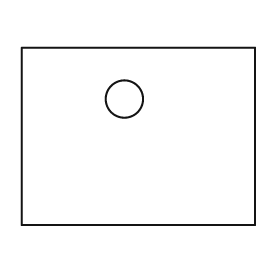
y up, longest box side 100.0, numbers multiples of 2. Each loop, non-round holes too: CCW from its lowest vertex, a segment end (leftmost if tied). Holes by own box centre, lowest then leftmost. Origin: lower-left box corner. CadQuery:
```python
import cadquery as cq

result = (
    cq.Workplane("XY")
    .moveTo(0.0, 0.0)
    .lineTo(100.0, 0.0)
    .lineTo(100.0, 76.0)
    .lineTo(0.0, 76.0)
    .close()
    .moveTo(44.0, 54.0)
    .circle(8.0)
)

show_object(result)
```